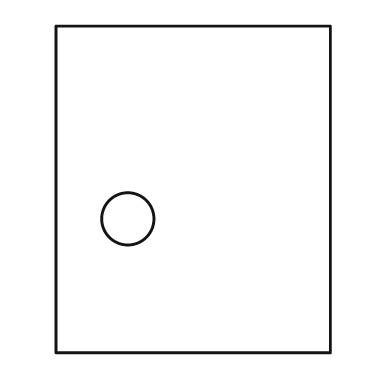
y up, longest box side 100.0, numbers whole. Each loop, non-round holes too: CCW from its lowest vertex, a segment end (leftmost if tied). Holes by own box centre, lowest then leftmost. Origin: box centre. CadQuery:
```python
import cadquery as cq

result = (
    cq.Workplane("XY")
    .moveTo(-42.0, -50.0)
    .lineTo(42.0, -50.0)
    .lineTo(42.0, 50.0)
    .lineTo(-42.0, 50.0)
    .close()
    .moveTo(-20.0, -9.0)
    .circle(8.0)
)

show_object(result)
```